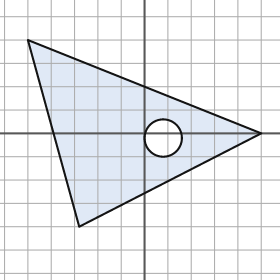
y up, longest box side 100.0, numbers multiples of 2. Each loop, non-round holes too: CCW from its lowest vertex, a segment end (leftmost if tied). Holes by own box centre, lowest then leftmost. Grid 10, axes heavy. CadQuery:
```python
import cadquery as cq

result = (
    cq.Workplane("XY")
    .moveTo(-28.0, -40.0)
    .lineTo(50.0, 0.0)
    .lineTo(-50.0, 40.0)
    .close()
    .moveTo(8.0, -2.0)
    .circle(8.0)
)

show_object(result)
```